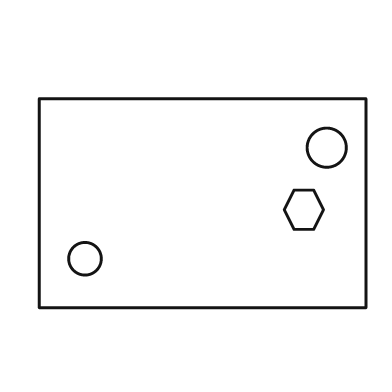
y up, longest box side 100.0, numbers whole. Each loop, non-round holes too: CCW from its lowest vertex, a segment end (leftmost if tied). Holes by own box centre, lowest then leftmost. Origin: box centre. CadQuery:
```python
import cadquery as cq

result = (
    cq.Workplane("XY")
    .moveTo(-50.0, -32.0)
    .lineTo(50.0, -32.0)
    .lineTo(50.0, 32.0)
    .lineTo(-50.0, 32.0)
    .close()
    .moveTo(-36.0, -17.0)
    .circle(5.0)
    .moveTo(28.0, -8.0)
    .lineTo(34.0, -8.0)
    .lineTo(37.0, -2.0)
    .lineTo(34.0, 4.0)
    .lineTo(28.0, 4.0)
    .lineTo(25.0, -2.0)
    .close()
    .moveTo(38.0, 17.0)
    .circle(6.0)
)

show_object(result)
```